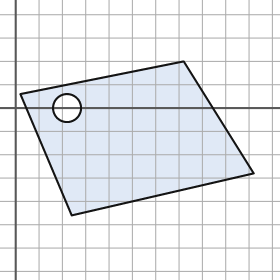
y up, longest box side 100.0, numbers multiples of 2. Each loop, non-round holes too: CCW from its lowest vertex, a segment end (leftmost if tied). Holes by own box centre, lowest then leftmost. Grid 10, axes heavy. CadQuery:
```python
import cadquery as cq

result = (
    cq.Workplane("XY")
    .moveTo(24.0, -46.0)
    .lineTo(102.0, -28.0)
    .lineTo(72.0, 20.0)
    .lineTo(2.0, 6.0)
    .close()
    .moveTo(22.0, 0.0)
    .circle(6.0)
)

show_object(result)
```